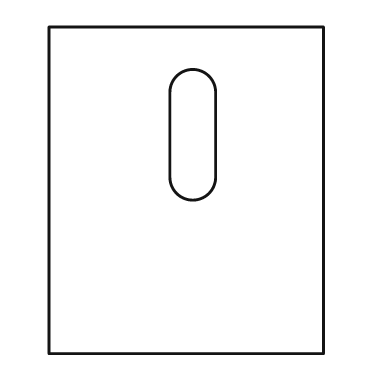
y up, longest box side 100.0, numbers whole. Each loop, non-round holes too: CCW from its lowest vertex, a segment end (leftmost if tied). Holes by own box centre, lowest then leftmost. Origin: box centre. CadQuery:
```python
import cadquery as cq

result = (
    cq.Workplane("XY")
    .moveTo(-42.0, -50.0)
    .lineTo(42.0, -50.0)
    .lineTo(42.0, 50.0)
    .lineTo(-42.0, 50.0)
    .close()
    .moveTo(-5.0, 4.0)
    .threePointArc((2.0, -3.0), (9.0, 4.0))
    .lineTo(9.0, 30.0)
    .threePointArc((2.0, 37.0), (-5.0, 30.0))
    .close()
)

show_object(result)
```